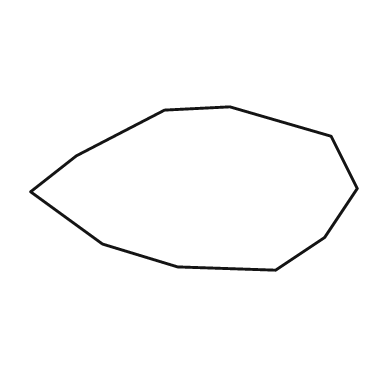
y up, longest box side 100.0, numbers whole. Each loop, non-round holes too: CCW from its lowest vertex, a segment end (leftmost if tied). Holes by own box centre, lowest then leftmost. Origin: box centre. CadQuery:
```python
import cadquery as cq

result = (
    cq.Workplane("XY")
    .moveTo(25.0, -25.0)
    .lineTo(40.0, -15.0)
    .lineTo(50.0, 0.0)
    .lineTo(42.0, 16.0)
    .lineTo(11.0, 25.0)
    .lineTo(-9.0, 24.0)
    .lineTo(-36.0, 10.0)
    .lineTo(-50.0, -1.0)
    .lineTo(-28.0, -17.0)
    .lineTo(-5.0, -24.0)
    .close()
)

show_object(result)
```